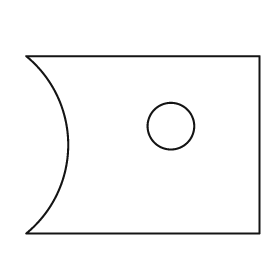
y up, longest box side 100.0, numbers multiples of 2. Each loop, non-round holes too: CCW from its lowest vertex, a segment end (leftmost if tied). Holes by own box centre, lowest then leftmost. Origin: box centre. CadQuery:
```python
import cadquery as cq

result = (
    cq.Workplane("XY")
    .moveTo(-50.0, -38.0)
    .lineTo(50.0, -38.0)
    .lineTo(50.0, 38.0)
    .lineTo(-50.0, 38.0)
    .threePointArc((-32.0, 0.0), (-50.0, -38.0))
    .close()
    .moveTo(12.0, 8.0)
    .circle(10.0)
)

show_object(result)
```